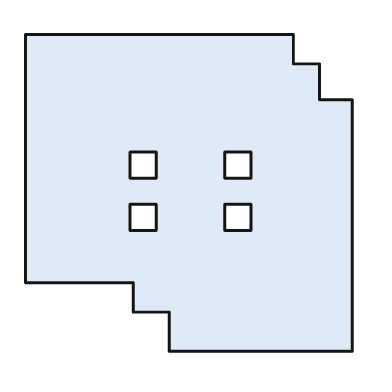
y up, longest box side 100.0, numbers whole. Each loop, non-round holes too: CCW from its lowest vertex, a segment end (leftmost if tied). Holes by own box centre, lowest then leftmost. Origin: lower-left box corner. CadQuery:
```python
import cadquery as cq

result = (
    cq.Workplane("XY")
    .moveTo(44.0, 0.0)
    .lineTo(100.0, 0.0)
    .lineTo(100.0, 77.0)
    .lineTo(90.0, 77.0)
    .lineTo(90.0, 88.0)
    .lineTo(82.0, 88.0)
    .lineTo(82.0, 97.0)
    .lineTo(0.0, 97.0)
    .lineTo(0.0, 21.0)
    .lineTo(33.0, 21.0)
    .lineTo(33.0, 12.0)
    .lineTo(44.0, 12.0)
    .close()
    .moveTo(32.0, 37.0)
    .lineTo(40.0, 37.0)
    .lineTo(40.0, 45.0)
    .lineTo(32.0, 45.0)
    .close()
    .moveTo(61.0, 37.0)
    .lineTo(69.0, 37.0)
    .lineTo(69.0, 45.0)
    .lineTo(61.0, 45.0)
    .close()
    .moveTo(32.0, 53.0)
    .lineTo(40.0, 53.0)
    .lineTo(40.0, 61.0)
    .lineTo(32.0, 61.0)
    .close()
    .moveTo(61.0, 53.0)
    .lineTo(69.0, 53.0)
    .lineTo(69.0, 61.0)
    .lineTo(61.0, 61.0)
    .close()
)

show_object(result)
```